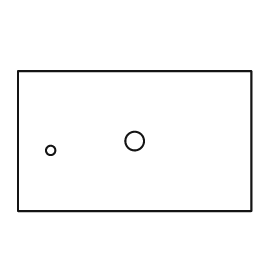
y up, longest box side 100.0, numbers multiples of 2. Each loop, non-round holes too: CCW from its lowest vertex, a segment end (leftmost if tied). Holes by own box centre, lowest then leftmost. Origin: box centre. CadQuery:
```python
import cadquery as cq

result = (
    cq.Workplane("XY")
    .moveTo(-50.0, -30.0)
    .lineTo(50.0, -30.0)
    .lineTo(50.0, 30.0)
    .lineTo(-50.0, 30.0)
    .close()
    .moveTo(-36.0, -4.0)
    .circle(2.0)
    .moveTo(0.0, 0.0)
    .circle(4.0)
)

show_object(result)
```